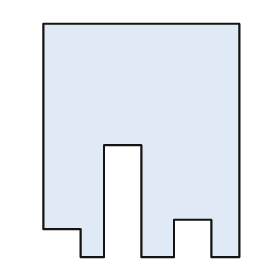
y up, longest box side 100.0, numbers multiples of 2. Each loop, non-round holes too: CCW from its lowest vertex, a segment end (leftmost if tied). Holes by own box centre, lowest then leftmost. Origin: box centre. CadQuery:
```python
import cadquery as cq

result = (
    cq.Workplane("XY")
    .moveTo(-26.0, -50.0)
    .lineTo(-16.0, -50.0)
    .lineTo(-16.0, -2.0)
    .lineTo(0.0, -2.0)
    .lineTo(0.0, -50.0)
    .lineTo(14.0, -50.0)
    .lineTo(14.0, -34.0)
    .lineTo(30.0, -34.0)
    .lineTo(30.0, -50.0)
    .lineTo(42.0, -50.0)
    .lineTo(42.0, 50.0)
    .lineTo(-42.0, 50.0)
    .lineTo(-42.0, -38.0)
    .lineTo(-26.0, -38.0)
    .close()
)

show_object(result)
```